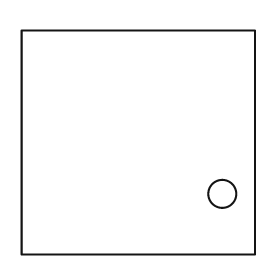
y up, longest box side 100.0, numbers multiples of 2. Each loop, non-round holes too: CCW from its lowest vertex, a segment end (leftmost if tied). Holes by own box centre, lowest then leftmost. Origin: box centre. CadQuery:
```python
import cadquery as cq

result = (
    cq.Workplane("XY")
    .moveTo(-50.0, -48.0)
    .lineTo(50.0, -48.0)
    .lineTo(50.0, 48.0)
    .lineTo(-50.0, 48.0)
    .close()
    .moveTo(36.0, -22.0)
    .circle(6.0)
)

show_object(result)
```